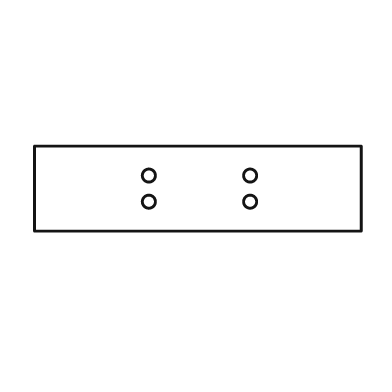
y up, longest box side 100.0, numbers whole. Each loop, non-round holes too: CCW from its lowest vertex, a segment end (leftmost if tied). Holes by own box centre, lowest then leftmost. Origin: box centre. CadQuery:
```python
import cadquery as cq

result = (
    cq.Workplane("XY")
    .moveTo(-50.0, -13.0)
    .lineTo(50.0, -13.0)
    .lineTo(50.0, 13.0)
    .lineTo(-50.0, 13.0)
    .close()
    .moveTo(-15.0, -4.0)
    .circle(2.0)
    .moveTo(16.0, -4.0)
    .circle(2.0)
    .moveTo(-15.0, 4.0)
    .circle(2.0)
    .moveTo(16.0, 4.0)
    .circle(2.0)
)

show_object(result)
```